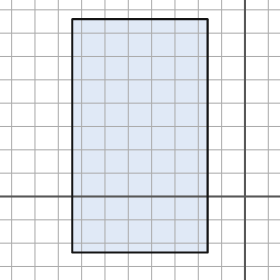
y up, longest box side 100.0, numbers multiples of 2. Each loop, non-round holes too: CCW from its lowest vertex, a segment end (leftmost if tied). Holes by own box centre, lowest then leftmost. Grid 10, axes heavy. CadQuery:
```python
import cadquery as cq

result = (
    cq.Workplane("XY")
    .moveTo(-74.0, -24.0)
    .lineTo(-16.0, -24.0)
    .lineTo(-16.0, 76.0)
    .lineTo(-74.0, 76.0)
    .close()
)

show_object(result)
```